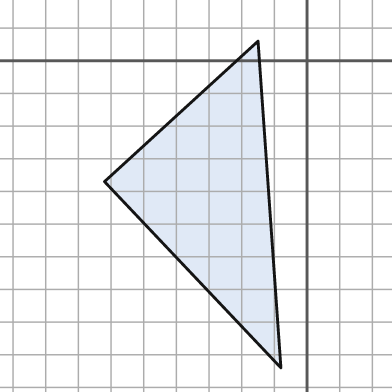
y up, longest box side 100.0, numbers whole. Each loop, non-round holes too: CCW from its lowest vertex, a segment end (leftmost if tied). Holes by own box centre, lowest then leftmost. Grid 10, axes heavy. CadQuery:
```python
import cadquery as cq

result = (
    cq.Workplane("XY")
    .moveTo(-8.0, -94.0)
    .lineTo(-15.0, 6.0)
    .lineTo(-62.0, -37.0)
    .close()
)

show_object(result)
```